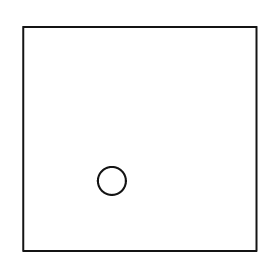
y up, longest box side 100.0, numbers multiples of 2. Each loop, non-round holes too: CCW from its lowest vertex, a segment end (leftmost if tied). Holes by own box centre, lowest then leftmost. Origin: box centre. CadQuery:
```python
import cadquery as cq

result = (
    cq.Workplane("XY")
    .moveTo(-50.0, -48.0)
    .lineTo(50.0, -48.0)
    .lineTo(50.0, 48.0)
    .lineTo(-50.0, 48.0)
    .close()
    .moveTo(-12.0, -18.0)
    .circle(6.0)
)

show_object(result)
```